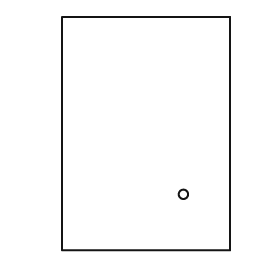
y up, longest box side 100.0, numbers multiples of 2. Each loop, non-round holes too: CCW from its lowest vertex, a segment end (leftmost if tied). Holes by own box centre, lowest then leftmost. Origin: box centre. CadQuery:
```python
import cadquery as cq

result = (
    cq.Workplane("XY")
    .moveTo(-36.0, -50.0)
    .lineTo(36.0, -50.0)
    .lineTo(36.0, 50.0)
    .lineTo(-36.0, 50.0)
    .close()
    .moveTo(16.0, -26.0)
    .circle(2.0)
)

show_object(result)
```